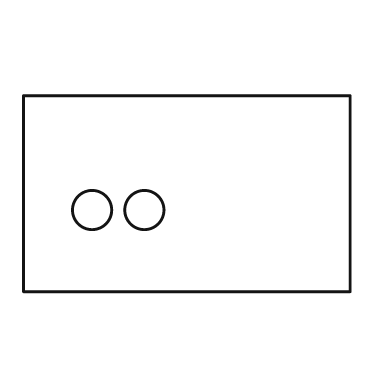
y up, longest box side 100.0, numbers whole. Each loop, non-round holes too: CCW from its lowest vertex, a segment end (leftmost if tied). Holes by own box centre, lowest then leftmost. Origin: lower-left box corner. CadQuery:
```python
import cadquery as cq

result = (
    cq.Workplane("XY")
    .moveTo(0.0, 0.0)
    .lineTo(100.0, 0.0)
    .lineTo(100.0, 60.0)
    .lineTo(0.0, 60.0)
    .close()
    .moveTo(21.0, 25.0)
    .circle(6.0)
    .moveTo(37.0, 25.0)
    .circle(6.0)
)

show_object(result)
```